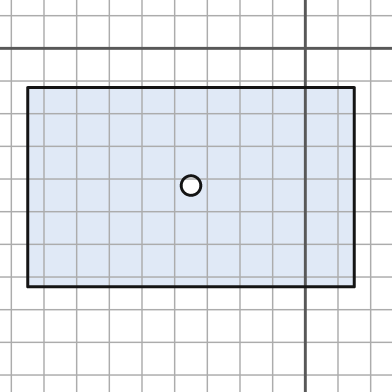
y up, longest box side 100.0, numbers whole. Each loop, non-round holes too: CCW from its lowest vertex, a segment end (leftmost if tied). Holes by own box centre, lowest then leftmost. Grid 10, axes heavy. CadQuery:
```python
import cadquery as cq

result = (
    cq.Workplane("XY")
    .moveTo(-85.0, -73.0)
    .lineTo(15.0, -73.0)
    .lineTo(15.0, -12.0)
    .lineTo(-85.0, -12.0)
    .close()
    .moveTo(-35.0, -42.0)
    .circle(3.0)
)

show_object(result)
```